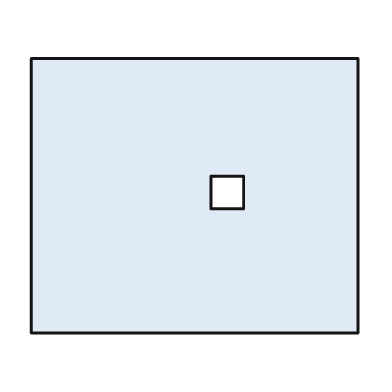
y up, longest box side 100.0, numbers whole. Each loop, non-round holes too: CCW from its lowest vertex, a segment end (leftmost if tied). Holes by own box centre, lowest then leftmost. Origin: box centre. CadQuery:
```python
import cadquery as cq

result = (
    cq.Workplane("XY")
    .moveTo(-50.0, -42.0)
    .lineTo(50.0, -42.0)
    .lineTo(50.0, 42.0)
    .lineTo(-50.0, 42.0)
    .close()
    .moveTo(5.0, -4.0)
    .lineTo(15.0, -4.0)
    .lineTo(15.0, 6.0)
    .lineTo(5.0, 6.0)
    .close()
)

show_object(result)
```